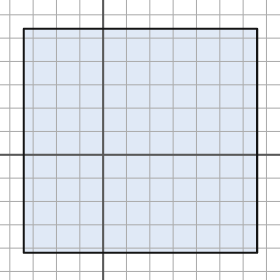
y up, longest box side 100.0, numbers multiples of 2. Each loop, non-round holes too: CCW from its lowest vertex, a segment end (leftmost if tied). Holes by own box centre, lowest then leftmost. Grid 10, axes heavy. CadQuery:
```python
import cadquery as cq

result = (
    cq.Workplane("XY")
    .moveTo(-34.0, -42.0)
    .lineTo(66.0, -42.0)
    .lineTo(66.0, 54.0)
    .lineTo(-34.0, 54.0)
    .close()
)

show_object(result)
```